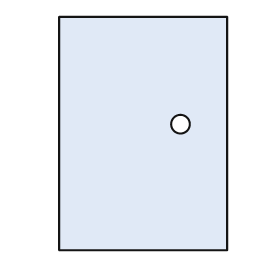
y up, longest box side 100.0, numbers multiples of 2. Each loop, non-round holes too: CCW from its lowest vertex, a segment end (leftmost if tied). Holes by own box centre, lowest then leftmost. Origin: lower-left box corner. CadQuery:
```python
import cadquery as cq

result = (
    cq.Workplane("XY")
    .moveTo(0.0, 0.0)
    .lineTo(72.0, 0.0)
    .lineTo(72.0, 100.0)
    .lineTo(0.0, 100.0)
    .close()
    .moveTo(52.0, 54.0)
    .circle(4.0)
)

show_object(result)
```